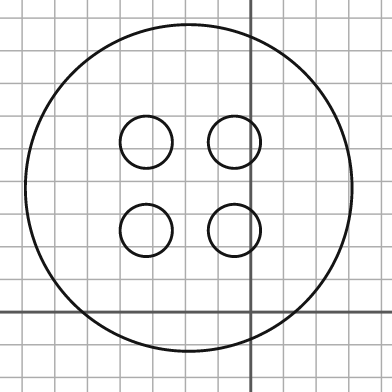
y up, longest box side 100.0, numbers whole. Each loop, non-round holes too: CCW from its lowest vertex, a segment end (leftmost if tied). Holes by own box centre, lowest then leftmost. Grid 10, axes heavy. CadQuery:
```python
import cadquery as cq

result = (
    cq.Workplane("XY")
    .moveTo(-19.0, 38.0)
    .circle(50.0)
    .moveTo(-32.0, 25.0)
    .circle(8.0)
    .moveTo(-5.0, 25.0)
    .circle(8.0)
    .moveTo(-32.0, 52.0)
    .circle(8.0)
    .moveTo(-5.0, 52.0)
    .circle(8.0)
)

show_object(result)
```